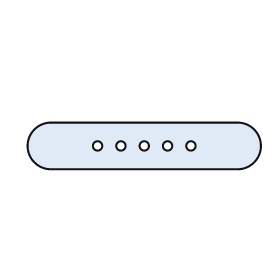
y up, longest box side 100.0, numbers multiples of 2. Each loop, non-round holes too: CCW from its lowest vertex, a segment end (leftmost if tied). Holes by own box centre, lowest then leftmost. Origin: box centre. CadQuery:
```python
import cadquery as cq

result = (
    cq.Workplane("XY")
    .moveTo(-40.0, -10.0)
    .lineTo(40.0, -10.0)
    .threePointArc((50.0, 0.0), (40.0, 10.0))
    .lineTo(-40.0, 10.0)
    .threePointArc((-50.0, 0.0), (-40.0, -10.0))
    .close()
    .moveTo(-20.0, 0.0)
    .circle(2.0)
    .moveTo(-10.0, 0.0)
    .circle(2.0)
    .moveTo(0.0, 0.0)
    .circle(2.0)
    .moveTo(10.0, 0.0)
    .circle(2.0)
    .moveTo(20.0, 0.0)
    .circle(2.0)
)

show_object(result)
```